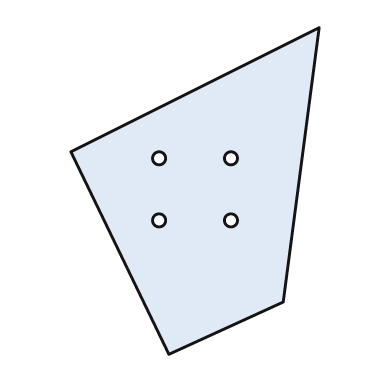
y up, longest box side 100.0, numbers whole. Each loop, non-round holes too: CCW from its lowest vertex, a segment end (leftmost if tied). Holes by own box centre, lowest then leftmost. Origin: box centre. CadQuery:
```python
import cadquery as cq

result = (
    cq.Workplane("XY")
    .moveTo(-8.0, -50.0)
    .lineTo(27.0, -34.0)
    .lineTo(38.0, 50.0)
    .lineTo(-38.0, 12.0)
    .close()
    .moveTo(-11.0, -9.0)
    .circle(2.0)
    .moveTo(11.0, -9.0)
    .circle(2.0)
    .moveTo(-11.0, 10.0)
    .circle(2.0)
    .moveTo(11.0, 10.0)
    .circle(2.0)
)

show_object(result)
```